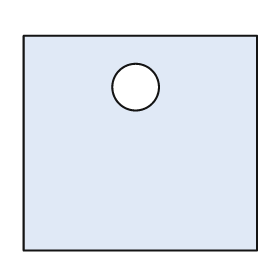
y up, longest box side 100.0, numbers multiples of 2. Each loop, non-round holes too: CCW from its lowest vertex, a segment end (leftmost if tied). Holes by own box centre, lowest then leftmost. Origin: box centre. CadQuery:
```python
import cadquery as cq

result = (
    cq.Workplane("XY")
    .moveTo(-50.0, -46.0)
    .lineTo(50.0, -46.0)
    .lineTo(50.0, 46.0)
    .lineTo(-50.0, 46.0)
    .close()
    .moveTo(-2.0, 24.0)
    .circle(10.0)
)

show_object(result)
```